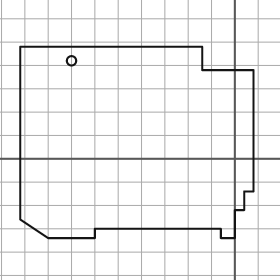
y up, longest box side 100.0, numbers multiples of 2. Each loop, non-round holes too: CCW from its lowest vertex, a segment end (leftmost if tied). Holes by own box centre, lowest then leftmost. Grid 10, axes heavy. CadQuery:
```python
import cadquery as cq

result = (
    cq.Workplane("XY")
    .moveTo(-80.0, -34.0)
    .lineTo(-60.0, -34.0)
    .lineTo(-60.0, -30.0)
    .lineTo(-6.0, -30.0)
    .lineTo(-6.0, -34.0)
    .lineTo(0.0, -34.0)
    .lineTo(0.0, -22.0)
    .lineTo(4.0, -22.0)
    .lineTo(4.0, -14.0)
    .lineTo(8.0, -14.0)
    .lineTo(8.0, 38.0)
    .lineTo(-14.0, 38.0)
    .lineTo(-14.0, 48.0)
    .lineTo(-92.0, 48.0)
    .lineTo(-92.0, -26.0)
    .close()
    .moveTo(-70.0, 42.0)
    .circle(2.0)
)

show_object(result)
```